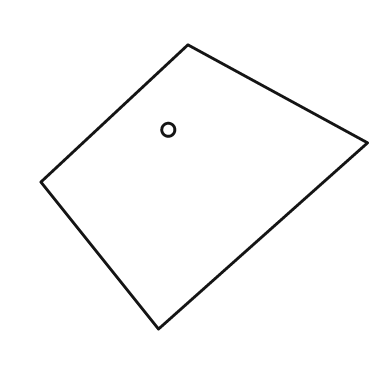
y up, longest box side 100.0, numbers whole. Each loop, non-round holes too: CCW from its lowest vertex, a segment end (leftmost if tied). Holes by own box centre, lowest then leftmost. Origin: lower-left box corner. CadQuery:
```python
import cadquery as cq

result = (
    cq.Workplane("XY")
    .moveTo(36.0, 0.0)
    .lineTo(100.0, 57.0)
    .lineTo(45.0, 87.0)
    .lineTo(0.0, 45.0)
    .close()
    .moveTo(39.0, 61.0)
    .circle(2.0)
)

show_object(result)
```